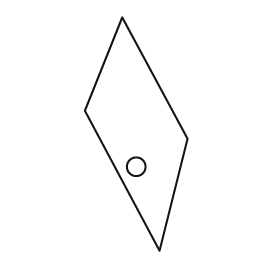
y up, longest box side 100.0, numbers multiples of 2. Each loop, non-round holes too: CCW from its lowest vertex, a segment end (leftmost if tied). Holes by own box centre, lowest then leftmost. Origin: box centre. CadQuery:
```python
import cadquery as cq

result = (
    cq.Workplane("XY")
    .moveTo(10.0, -50.0)
    .lineTo(22.0, -2.0)
    .lineTo(-6.0, 50.0)
    .lineTo(-22.0, 10.0)
    .close()
    .moveTo(0.0, -14.0)
    .circle(4.0)
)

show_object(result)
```